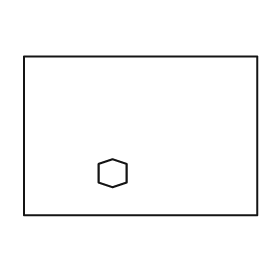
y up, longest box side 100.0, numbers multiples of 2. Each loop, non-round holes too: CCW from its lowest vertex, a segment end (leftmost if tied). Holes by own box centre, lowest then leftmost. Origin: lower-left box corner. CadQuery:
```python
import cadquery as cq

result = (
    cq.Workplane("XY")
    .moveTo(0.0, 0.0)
    .lineTo(100.0, 0.0)
    .lineTo(100.0, 68.0)
    .lineTo(0.0, 68.0)
    .close()
    .moveTo(38.0, 12.0)
    .lineTo(44.0, 14.0)
    .lineTo(44.0, 22.0)
    .lineTo(38.0, 24.0)
    .lineTo(32.0, 22.0)
    .lineTo(32.0, 14.0)
    .close()
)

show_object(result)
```